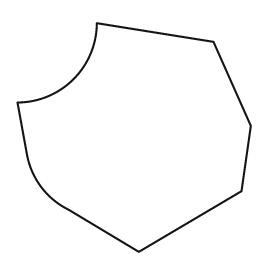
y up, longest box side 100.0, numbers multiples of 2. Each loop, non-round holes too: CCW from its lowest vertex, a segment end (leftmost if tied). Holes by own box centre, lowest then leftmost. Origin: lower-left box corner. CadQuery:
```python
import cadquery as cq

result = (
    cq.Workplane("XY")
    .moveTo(52.0, 0.0)
    .lineTo(96.0, 26.0)
    .lineTo(100.0, 54.0)
    .lineTo(84.0, 90.0)
    .lineTo(34.0, 98.0)
    .threePointArc((24.0, 74.0), (0.0, 64.0))
    .lineTo(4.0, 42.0)
    .threePointArc((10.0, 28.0), (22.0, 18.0))
    .close()
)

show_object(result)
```